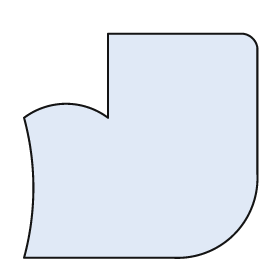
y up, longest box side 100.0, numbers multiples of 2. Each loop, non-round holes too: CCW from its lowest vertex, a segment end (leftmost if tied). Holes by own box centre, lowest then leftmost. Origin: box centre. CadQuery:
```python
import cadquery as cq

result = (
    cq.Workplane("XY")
    .moveTo(-50.0, -48.0)
    .lineTo(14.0, -48.0)
    .threePointArc((40.0, -38.0), (50.0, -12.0))
    .lineTo(50.0, 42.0)
    .threePointArc((48.0, 46.0), (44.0, 48.0))
    .lineTo(-14.0, 48.0)
    .lineTo(-14.0, 12.0)
    .threePointArc((-32.0, 18.0), (-50.0, 12.0))
    .threePointArc((-46.0, -18.0), (-50.0, -48.0))
    .close()
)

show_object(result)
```